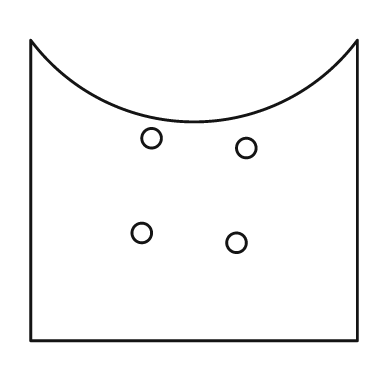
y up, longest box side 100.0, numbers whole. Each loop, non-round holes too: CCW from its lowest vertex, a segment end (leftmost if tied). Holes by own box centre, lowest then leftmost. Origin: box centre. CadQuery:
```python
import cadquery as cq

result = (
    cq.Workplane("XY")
    .moveTo(-50.0, -46.0)
    .lineTo(50.0, -46.0)
    .lineTo(50.0, 46.0)
    .threePointArc((0.0, 21.0), (-50.0, 46.0))
    .close()
    .moveTo(13.0, -16.0)
    .circle(3.0)
    .moveTo(-16.0, -13.0)
    .circle(3.0)
    .moveTo(16.0, 13.0)
    .circle(3.0)
    .moveTo(-13.0, 16.0)
    .circle(3.0)
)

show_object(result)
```